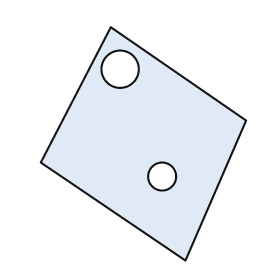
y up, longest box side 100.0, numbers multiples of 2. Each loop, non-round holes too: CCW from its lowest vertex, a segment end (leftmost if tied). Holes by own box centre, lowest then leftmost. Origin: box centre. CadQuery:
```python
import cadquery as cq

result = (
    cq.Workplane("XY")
    .moveTo(18.0, -50.0)
    .lineTo(44.0, 10.0)
    .lineTo(-14.0, 50.0)
    .lineTo(-44.0, -8.0)
    .close()
    .moveTo(8.0, -14.0)
    .circle(6.0)
    .moveTo(-10.0, 32.0)
    .circle(8.0)
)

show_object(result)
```